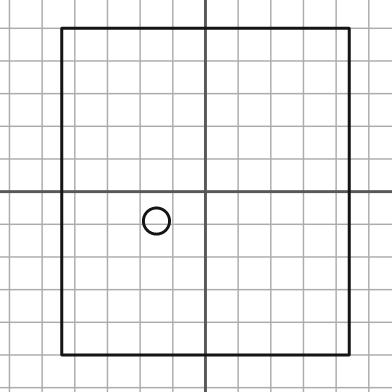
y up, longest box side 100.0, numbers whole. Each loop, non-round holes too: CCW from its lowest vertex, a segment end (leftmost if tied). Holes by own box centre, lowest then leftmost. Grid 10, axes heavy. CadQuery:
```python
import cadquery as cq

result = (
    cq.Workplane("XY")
    .moveTo(-44.0, -50.0)
    .lineTo(44.0, -50.0)
    .lineTo(44.0, 50.0)
    .lineTo(-44.0, 50.0)
    .close()
    .moveTo(-15.0, -9.0)
    .circle(4.0)
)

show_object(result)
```